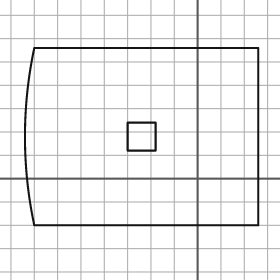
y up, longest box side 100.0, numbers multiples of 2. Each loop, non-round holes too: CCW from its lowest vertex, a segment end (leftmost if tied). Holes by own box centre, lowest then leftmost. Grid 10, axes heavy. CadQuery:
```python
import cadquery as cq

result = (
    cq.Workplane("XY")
    .moveTo(-70.0, -20.0)
    .lineTo(26.0, -20.0)
    .lineTo(26.0, 56.0)
    .lineTo(-70.0, 56.0)
    .threePointArc((-74.0, 18.0), (-70.0, -20.0))
    .close()
    .moveTo(-30.0, 12.0)
    .lineTo(-18.0, 12.0)
    .lineTo(-18.0, 24.0)
    .lineTo(-30.0, 24.0)
    .close()
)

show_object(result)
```